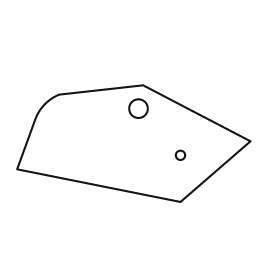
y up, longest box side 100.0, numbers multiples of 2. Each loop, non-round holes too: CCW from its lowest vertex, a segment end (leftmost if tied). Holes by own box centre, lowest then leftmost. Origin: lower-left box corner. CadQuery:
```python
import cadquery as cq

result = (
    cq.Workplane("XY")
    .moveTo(70.0, 0.0)
    .lineTo(100.0, 26.0)
    .lineTo(54.0, 50.0)
    .lineTo(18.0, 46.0)
    .threePointArc((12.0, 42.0), (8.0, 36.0))
    .lineTo(0.0, 14.0)
    .close()
    .moveTo(70.0, 20.0)
    .circle(2.0)
    .moveTo(52.0, 40.0)
    .circle(4.0)
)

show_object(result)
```